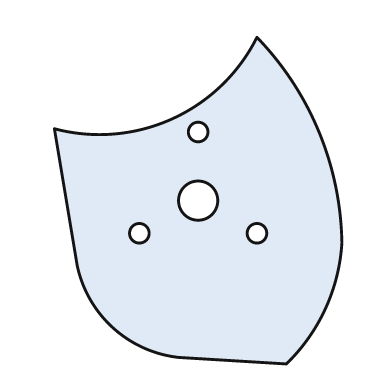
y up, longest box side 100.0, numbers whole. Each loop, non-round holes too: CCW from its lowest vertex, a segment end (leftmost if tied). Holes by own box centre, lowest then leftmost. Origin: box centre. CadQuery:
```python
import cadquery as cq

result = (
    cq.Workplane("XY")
    .moveTo(27.0, -50.0)
    .threePointArc((39.0, -33.0), (44.0, -13.0))
    .threePointArc((37.0, 21.0), (18.0, 50.0))
    .threePointArc((-8.0, 25.0), (-44.0, 22.0))
    .lineTo(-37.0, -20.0)
    .threePointArc((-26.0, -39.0), (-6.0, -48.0))
    .close()
    .moveTo(-18.0, -10.0)
    .circle(3.0)
    .moveTo(18.0, -10.0)
    .circle(3.0)
    .moveTo(0.0, 0.0)
    .circle(6.0)
    .moveTo(0.0, 21.0)
    .circle(3.0)
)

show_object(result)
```